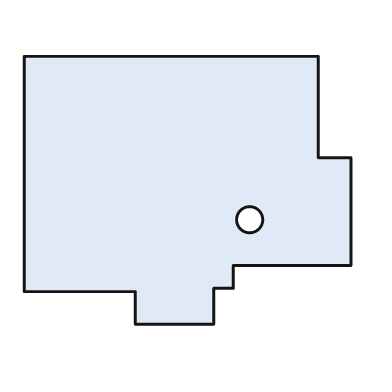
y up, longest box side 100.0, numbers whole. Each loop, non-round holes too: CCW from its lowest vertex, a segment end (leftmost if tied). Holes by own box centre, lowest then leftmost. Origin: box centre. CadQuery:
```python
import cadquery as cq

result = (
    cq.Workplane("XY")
    .moveTo(-16.0, -41.0)
    .lineTo(8.0, -41.0)
    .lineTo(8.0, -30.0)
    .lineTo(14.0, -30.0)
    .lineTo(14.0, -23.0)
    .lineTo(50.0, -23.0)
    .lineTo(50.0, 10.0)
    .lineTo(40.0, 10.0)
    .lineTo(40.0, 41.0)
    .lineTo(-50.0, 41.0)
    .lineTo(-50.0, -31.0)
    .lineTo(-16.0, -31.0)
    .close()
    .moveTo(19.0, -9.0)
    .circle(4.0)
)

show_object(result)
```